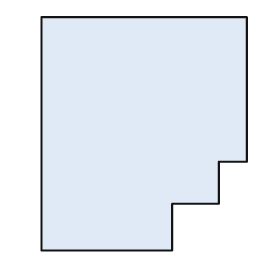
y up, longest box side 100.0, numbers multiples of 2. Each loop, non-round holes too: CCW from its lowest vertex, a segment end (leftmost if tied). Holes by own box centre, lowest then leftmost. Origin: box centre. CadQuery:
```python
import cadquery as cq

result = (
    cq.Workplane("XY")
    .moveTo(-44.0, -50.0)
    .lineTo(12.0, -50.0)
    .lineTo(12.0, -30.0)
    .lineTo(32.0, -30.0)
    .lineTo(32.0, -12.0)
    .lineTo(44.0, -12.0)
    .lineTo(44.0, 50.0)
    .lineTo(-44.0, 50.0)
    .close()
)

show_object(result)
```